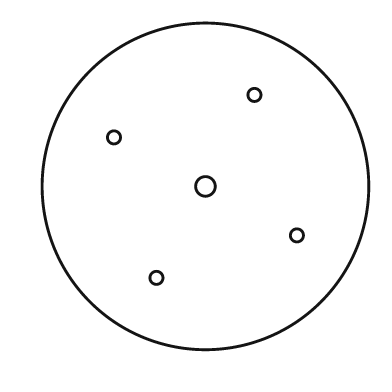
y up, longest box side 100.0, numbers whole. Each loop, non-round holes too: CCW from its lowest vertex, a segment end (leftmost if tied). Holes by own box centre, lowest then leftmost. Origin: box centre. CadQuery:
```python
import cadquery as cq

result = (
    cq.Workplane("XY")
    .moveTo(0.0, 0.0)
    .circle(50.0)
    .moveTo(-15.0, -28.0)
    .circle(2.0)
    .moveTo(28.0, -15.0)
    .circle(2.0)
    .moveTo(0.0, 0.0)
    .circle(3.0)
    .moveTo(-28.0, 15.0)
    .circle(2.0)
    .moveTo(15.0, 28.0)
    .circle(2.0)
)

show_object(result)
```